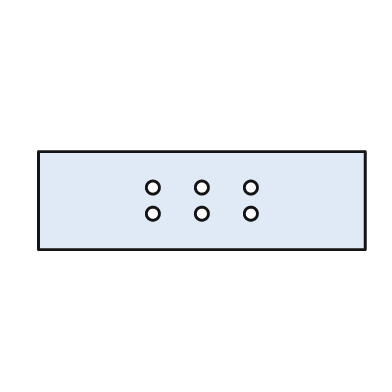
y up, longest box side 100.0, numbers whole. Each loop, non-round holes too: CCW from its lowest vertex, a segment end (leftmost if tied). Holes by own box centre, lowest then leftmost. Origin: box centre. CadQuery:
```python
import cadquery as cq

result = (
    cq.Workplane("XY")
    .moveTo(-50.0, -15.0)
    .lineTo(50.0, -15.0)
    .lineTo(50.0, 15.0)
    .lineTo(-50.0, 15.0)
    .close()
    .moveTo(-15.0, -4.0)
    .circle(2.0)
    .moveTo(0.0, -4.0)
    .circle(2.0)
    .moveTo(15.0, -4.0)
    .circle(2.0)
    .moveTo(-15.0, 4.0)
    .circle(2.0)
    .moveTo(0.0, 4.0)
    .circle(2.0)
    .moveTo(15.0, 4.0)
    .circle(2.0)
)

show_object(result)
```